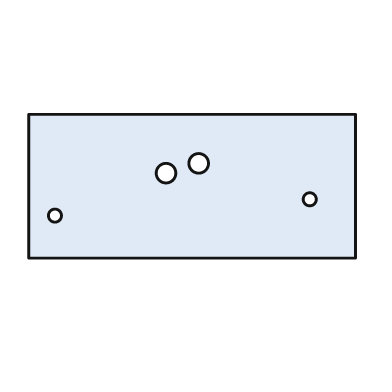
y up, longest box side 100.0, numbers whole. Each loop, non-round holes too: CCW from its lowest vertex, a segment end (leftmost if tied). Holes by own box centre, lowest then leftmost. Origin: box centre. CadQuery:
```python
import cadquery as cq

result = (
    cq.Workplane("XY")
    .moveTo(-50.0, -22.0)
    .lineTo(50.0, -22.0)
    .lineTo(50.0, 22.0)
    .lineTo(-50.0, 22.0)
    .close()
    .moveTo(-42.0, -9.0)
    .circle(2.0)
    .moveTo(36.0, -4.0)
    .circle(2.0)
    .moveTo(-8.0, 4.0)
    .circle(3.0)
    .moveTo(2.0, 7.0)
    .circle(3.0)
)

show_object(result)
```